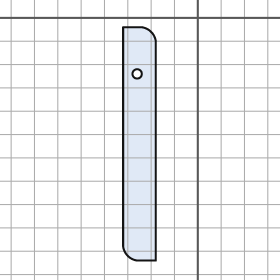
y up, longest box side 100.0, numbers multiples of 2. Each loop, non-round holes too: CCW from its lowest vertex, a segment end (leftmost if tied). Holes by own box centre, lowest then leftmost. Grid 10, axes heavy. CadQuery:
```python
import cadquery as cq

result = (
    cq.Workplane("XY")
    .moveTo(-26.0, -104.0)
    .lineTo(-18.0, -104.0)
    .lineTo(-18.0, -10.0)
    .threePointArc((-20.0, -6.0), (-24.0, -4.0))
    .lineTo(-32.0, -4.0)
    .lineTo(-32.0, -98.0)
    .threePointArc((-30.0, -102.0), (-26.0, -104.0))
    .close()
    .moveTo(-26.0, -24.0)
    .circle(2.0)
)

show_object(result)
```